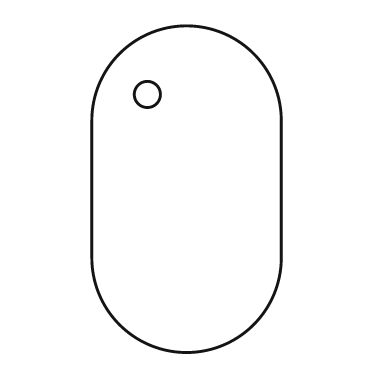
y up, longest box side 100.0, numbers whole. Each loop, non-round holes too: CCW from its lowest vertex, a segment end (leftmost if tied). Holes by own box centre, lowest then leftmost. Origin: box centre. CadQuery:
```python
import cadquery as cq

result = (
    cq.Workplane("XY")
    .moveTo(-29.0, -21.0)
    .threePointArc((0.0, -50.0), (29.0, -21.0))
    .lineTo(29.0, 21.0)
    .threePointArc((0.0, 50.0), (-29.0, 21.0))
    .close()
    .moveTo(-12.0, 29.0)
    .circle(4.0)
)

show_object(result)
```